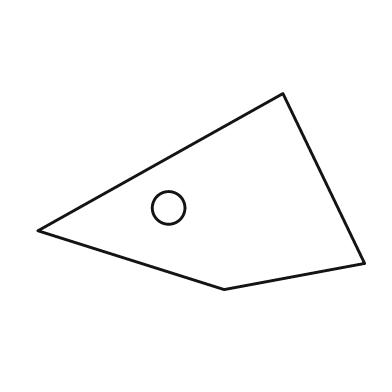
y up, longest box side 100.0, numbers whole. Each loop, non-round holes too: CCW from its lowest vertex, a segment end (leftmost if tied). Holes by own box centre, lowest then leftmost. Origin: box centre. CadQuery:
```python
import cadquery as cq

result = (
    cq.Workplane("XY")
    .moveTo(7.0, -30.0)
    .lineTo(50.0, -22.0)
    .lineTo(25.0, 30.0)
    .lineTo(-50.0, -12.0)
    .close()
    .moveTo(-10.0, -5.0)
    .circle(5.0)
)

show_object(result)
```